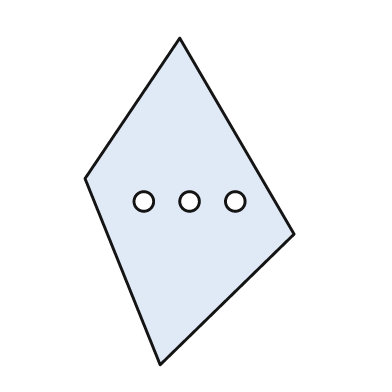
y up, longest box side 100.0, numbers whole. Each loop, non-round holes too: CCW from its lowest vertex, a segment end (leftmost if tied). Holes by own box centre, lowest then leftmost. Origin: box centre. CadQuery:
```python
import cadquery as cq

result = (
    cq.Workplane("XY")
    .moveTo(-9.0, -50.0)
    .lineTo(32.0, -10.0)
    .lineTo(-3.0, 50.0)
    .lineTo(-32.0, 7.0)
    .close()
    .moveTo(-14.0, 0.0)
    .circle(3.0)
    .moveTo(0.0, 0.0)
    .circle(3.0)
    .moveTo(14.0, 0.0)
    .circle(3.0)
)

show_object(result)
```